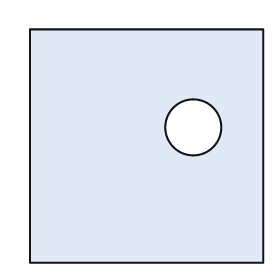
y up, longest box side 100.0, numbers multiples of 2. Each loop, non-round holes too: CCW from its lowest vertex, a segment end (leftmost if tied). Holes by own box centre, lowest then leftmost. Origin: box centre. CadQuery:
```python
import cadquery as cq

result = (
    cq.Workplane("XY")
    .moveTo(-50.0, -50.0)
    .lineTo(50.0, -50.0)
    .lineTo(50.0, 50.0)
    .lineTo(-50.0, 50.0)
    .close()
    .moveTo(20.0, 8.0)
    .circle(12.0)
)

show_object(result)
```